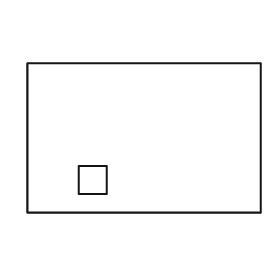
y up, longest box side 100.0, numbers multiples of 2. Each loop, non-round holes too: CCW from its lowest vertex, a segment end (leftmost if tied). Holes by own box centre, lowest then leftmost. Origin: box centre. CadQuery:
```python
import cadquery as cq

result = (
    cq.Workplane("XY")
    .moveTo(-50.0, -32.0)
    .lineTo(50.0, -32.0)
    .lineTo(50.0, 32.0)
    .lineTo(-50.0, 32.0)
    .close()
    .moveTo(-28.0, -24.0)
    .lineTo(-16.0, -24.0)
    .lineTo(-16.0, -12.0)
    .lineTo(-28.0, -12.0)
    .close()
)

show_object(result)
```